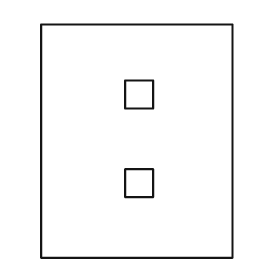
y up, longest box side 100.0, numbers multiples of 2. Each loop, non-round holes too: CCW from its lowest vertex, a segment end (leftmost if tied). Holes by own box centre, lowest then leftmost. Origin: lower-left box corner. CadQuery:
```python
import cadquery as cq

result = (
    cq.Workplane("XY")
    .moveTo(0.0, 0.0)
    .lineTo(82.0, 0.0)
    .lineTo(82.0, 100.0)
    .lineTo(0.0, 100.0)
    .close()
    .moveTo(36.0, 26.0)
    .lineTo(48.0, 26.0)
    .lineTo(48.0, 38.0)
    .lineTo(36.0, 38.0)
    .close()
    .moveTo(36.0, 64.0)
    .lineTo(48.0, 64.0)
    .lineTo(48.0, 76.0)
    .lineTo(36.0, 76.0)
    .close()
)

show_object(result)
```